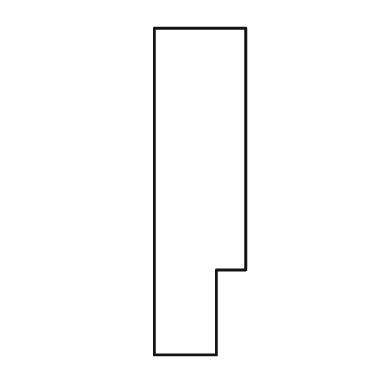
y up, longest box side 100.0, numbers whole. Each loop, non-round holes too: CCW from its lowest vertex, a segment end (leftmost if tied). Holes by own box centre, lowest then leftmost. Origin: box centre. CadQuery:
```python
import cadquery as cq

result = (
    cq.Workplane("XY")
    .moveTo(-14.0, -50.0)
    .lineTo(5.0, -50.0)
    .lineTo(5.0, -24.0)
    .lineTo(14.0, -24.0)
    .lineTo(14.0, 50.0)
    .lineTo(-14.0, 50.0)
    .close()
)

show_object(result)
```